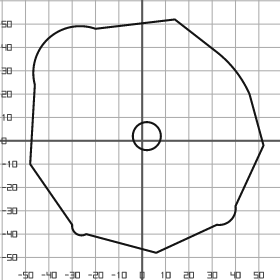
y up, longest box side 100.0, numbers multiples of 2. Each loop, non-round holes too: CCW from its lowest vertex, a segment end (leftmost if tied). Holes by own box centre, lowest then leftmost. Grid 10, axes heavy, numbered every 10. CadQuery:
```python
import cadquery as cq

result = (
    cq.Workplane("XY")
    .moveTo(6.0, -48.0)
    .lineTo(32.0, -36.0)
    .threePointArc((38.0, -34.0), (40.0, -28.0))
    .lineTo(52.0, -2.0)
    .lineTo(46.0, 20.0)
    .threePointArc((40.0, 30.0), (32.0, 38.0))
    .lineTo(14.0, 52.0)
    .lineTo(-20.0, 48.0)
    .threePointArc((-40.0, 44.0), (-46.0, 24.0))
    .lineTo(-48.0, -10.0)
    .lineTo(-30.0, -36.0)
    .threePointArc((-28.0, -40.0), (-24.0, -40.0))
    .close()
    .moveTo(2.0, 2.0)
    .circle(6.0)
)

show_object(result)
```